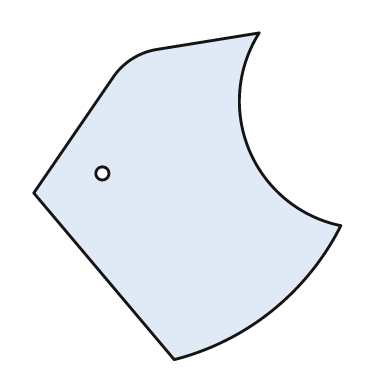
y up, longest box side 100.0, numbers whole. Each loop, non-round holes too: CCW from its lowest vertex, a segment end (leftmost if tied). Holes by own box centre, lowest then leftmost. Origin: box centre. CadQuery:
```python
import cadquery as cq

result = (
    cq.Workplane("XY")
    .moveTo(-4.0, -50.0)
    .threePointArc((26.0, -35.0), (47.0, -9.0))
    .threePointArc((19.0, 14.0), (22.0, 50.0))
    .lineTo(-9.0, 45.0)
    .threePointArc((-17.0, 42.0), (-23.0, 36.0))
    .lineTo(-47.0, 1.0)
    .close()
    .moveTo(-26.0, 7.0)
    .circle(2.0)
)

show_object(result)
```